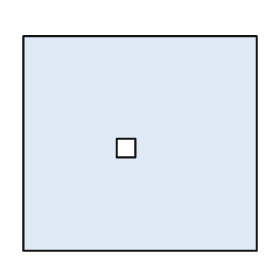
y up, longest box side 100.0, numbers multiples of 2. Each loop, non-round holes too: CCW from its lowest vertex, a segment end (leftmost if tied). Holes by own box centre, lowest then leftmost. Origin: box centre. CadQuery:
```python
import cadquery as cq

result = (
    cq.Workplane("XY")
    .moveTo(-50.0, -46.0)
    .lineTo(50.0, -46.0)
    .lineTo(50.0, 46.0)
    .lineTo(-50.0, 46.0)
    .close()
    .moveTo(-10.0, -6.0)
    .lineTo(-2.0, -6.0)
    .lineTo(-2.0, 2.0)
    .lineTo(-10.0, 2.0)
    .close()
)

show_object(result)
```